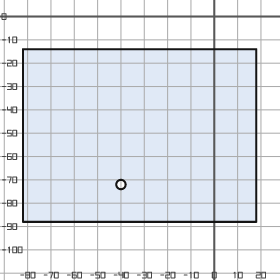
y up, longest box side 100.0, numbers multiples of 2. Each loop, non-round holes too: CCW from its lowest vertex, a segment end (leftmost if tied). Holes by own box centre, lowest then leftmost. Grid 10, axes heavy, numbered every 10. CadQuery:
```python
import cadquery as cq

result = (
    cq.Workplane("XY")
    .moveTo(-82.0, -88.0)
    .lineTo(18.0, -88.0)
    .lineTo(18.0, -14.0)
    .lineTo(-82.0, -14.0)
    .close()
    .moveTo(-40.0, -72.0)
    .circle(2.0)
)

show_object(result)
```